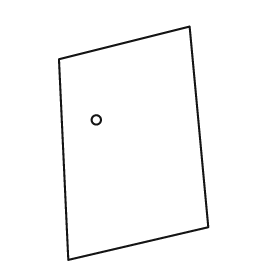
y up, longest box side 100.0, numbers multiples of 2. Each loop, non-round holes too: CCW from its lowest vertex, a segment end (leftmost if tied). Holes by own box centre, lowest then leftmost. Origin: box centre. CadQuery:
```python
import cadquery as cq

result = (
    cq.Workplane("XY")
    .moveTo(-28.0, -50.0)
    .lineTo(32.0, -36.0)
    .lineTo(24.0, 50.0)
    .lineTo(-32.0, 36.0)
    .close()
    .moveTo(-16.0, 10.0)
    .circle(2.0)
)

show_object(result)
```